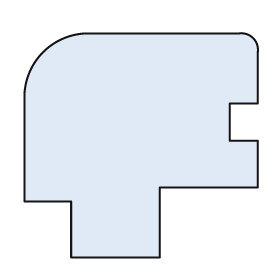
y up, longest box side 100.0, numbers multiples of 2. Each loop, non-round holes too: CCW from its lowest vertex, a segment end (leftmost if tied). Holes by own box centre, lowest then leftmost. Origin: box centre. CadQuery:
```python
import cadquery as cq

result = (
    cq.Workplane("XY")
    .moveTo(-30.0, -48.0)
    .lineTo(8.0, -48.0)
    .lineTo(8.0, -18.0)
    .lineTo(50.0, -18.0)
    .lineTo(50.0, 2.0)
    .lineTo(38.0, 2.0)
    .lineTo(38.0, 18.0)
    .lineTo(50.0, 18.0)
    .lineTo(50.0, 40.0)
    .threePointArc((48.0, 46.0), (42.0, 48.0))
    .lineTo(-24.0, 48.0)
    .threePointArc((-42.0, 40.0), (-50.0, 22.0))
    .lineTo(-50.0, -24.0)
    .lineTo(-30.0, -24.0)
    .close()
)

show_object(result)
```